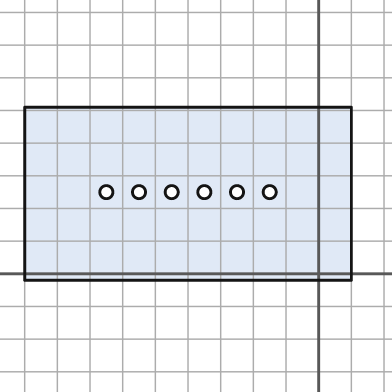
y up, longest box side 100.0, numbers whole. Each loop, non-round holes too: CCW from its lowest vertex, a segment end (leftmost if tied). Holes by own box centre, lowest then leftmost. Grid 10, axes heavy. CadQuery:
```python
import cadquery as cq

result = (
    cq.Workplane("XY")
    .moveTo(-90.0, -2.0)
    .lineTo(10.0, -2.0)
    .lineTo(10.0, 51.0)
    .lineTo(-90.0, 51.0)
    .close()
    .moveTo(-65.0, 25.0)
    .circle(2.0)
    .moveTo(-55.0, 25.0)
    .circle(2.0)
    .moveTo(-45.0, 25.0)
    .circle(2.0)
    .moveTo(-35.0, 25.0)
    .circle(2.0)
    .moveTo(-25.0, 25.0)
    .circle(2.0)
    .moveTo(-15.0, 25.0)
    .circle(2.0)
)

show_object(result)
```